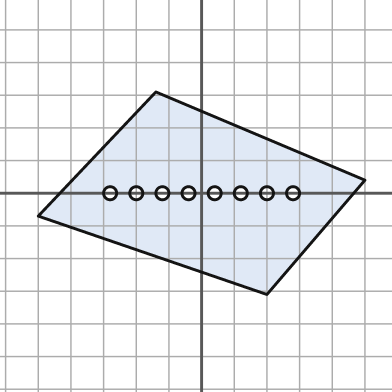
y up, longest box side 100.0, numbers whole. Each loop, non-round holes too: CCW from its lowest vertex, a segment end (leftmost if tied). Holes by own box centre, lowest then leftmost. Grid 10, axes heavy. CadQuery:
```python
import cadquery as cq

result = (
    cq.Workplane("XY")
    .moveTo(20.0, -31.0)
    .lineTo(50.0, 4.0)
    .lineTo(-14.0, 31.0)
    .lineTo(-50.0, -7.0)
    .close()
    .moveTo(-28.0, 0.0)
    .circle(2.0)
    .moveTo(-20.0, 0.0)
    .circle(2.0)
    .moveTo(-12.0, 0.0)
    .circle(2.0)
    .moveTo(-4.0, 0.0)
    .circle(2.0)
    .moveTo(4.0, 0.0)
    .circle(2.0)
    .moveTo(12.0, 0.0)
    .circle(2.0)
    .moveTo(20.0, 0.0)
    .circle(2.0)
    .moveTo(28.0, 0.0)
    .circle(2.0)
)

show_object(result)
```